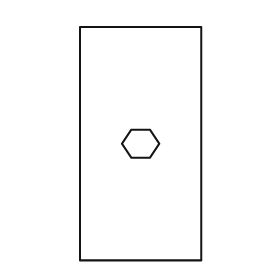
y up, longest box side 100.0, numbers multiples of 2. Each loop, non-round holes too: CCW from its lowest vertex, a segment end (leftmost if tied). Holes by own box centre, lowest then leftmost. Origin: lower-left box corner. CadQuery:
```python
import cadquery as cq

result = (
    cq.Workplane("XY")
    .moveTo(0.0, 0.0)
    .lineTo(52.0, 0.0)
    .lineTo(52.0, 100.0)
    .lineTo(0.0, 100.0)
    .close()
    .moveTo(22.0, 44.0)
    .lineTo(30.0, 44.0)
    .lineTo(34.0, 50.0)
    .lineTo(30.0, 56.0)
    .lineTo(22.0, 56.0)
    .lineTo(18.0, 50.0)
    .close()
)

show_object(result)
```